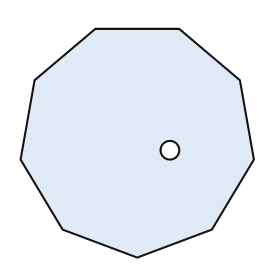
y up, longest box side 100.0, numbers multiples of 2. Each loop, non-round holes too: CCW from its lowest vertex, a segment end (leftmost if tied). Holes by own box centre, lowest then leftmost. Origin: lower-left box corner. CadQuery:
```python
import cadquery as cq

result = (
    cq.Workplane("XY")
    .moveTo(50.0, 0.0)
    .lineTo(82.0, 12.0)
    .lineTo(100.0, 42.0)
    .lineTo(94.0, 76.0)
    .lineTo(68.0, 98.0)
    .lineTo(32.0, 98.0)
    .lineTo(6.0, 76.0)
    .lineTo(0.0, 42.0)
    .lineTo(18.0, 12.0)
    .close()
    .moveTo(64.0, 46.0)
    .circle(4.0)
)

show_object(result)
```